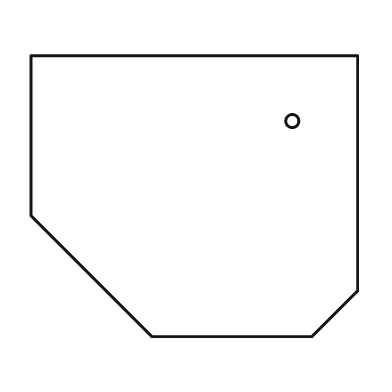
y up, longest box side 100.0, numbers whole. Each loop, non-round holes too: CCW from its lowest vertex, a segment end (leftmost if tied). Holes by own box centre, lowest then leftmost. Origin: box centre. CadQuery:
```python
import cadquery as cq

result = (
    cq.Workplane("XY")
    .moveTo(-13.0, -43.0)
    .lineTo(36.0, -43.0)
    .lineTo(50.0, -29.0)
    .lineTo(50.0, 43.0)
    .lineTo(-50.0, 43.0)
    .lineTo(-50.0, -6.0)
    .close()
    .moveTo(30.0, 23.0)
    .circle(2.0)
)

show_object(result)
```